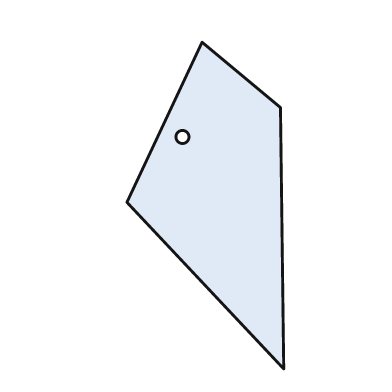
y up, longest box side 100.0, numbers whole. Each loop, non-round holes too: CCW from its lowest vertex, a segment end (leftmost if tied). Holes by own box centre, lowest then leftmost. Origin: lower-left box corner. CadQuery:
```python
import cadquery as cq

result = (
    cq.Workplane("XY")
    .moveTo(48.0, 0.0)
    .lineTo(47.0, 80.0)
    .lineTo(23.0, 100.0)
    .lineTo(0.0, 51.0)
    .close()
    .moveTo(17.0, 71.0)
    .circle(2.0)
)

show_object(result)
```